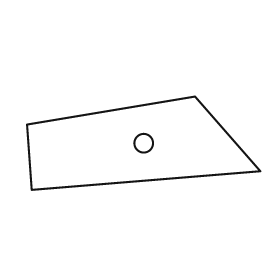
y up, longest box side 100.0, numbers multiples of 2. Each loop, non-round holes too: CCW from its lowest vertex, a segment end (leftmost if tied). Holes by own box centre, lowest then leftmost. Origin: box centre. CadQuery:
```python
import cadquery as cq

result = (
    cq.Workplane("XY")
    .moveTo(-48.0, -20.0)
    .lineTo(50.0, -12.0)
    .lineTo(22.0, 20.0)
    .lineTo(-50.0, 8.0)
    .close()
    .moveTo(0.0, 0.0)
    .circle(4.0)
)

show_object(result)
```